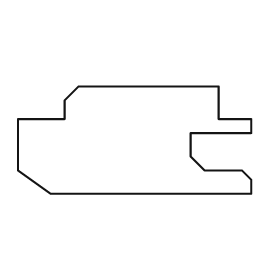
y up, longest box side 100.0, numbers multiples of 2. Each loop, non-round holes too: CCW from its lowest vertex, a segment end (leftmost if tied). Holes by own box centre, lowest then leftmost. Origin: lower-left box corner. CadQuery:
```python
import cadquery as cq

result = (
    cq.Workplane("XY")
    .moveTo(14.0, 0.0)
    .lineTo(100.0, 0.0)
    .lineTo(100.0, 6.0)
    .lineTo(96.0, 10.0)
    .lineTo(80.0, 10.0)
    .lineTo(74.0, 16.0)
    .lineTo(74.0, 26.0)
    .lineTo(100.0, 26.0)
    .lineTo(100.0, 32.0)
    .lineTo(86.0, 32.0)
    .lineTo(86.0, 46.0)
    .lineTo(26.0, 46.0)
    .lineTo(20.0, 40.0)
    .lineTo(20.0, 32.0)
    .lineTo(0.0, 32.0)
    .lineTo(0.0, 10.0)
    .close()
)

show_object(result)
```